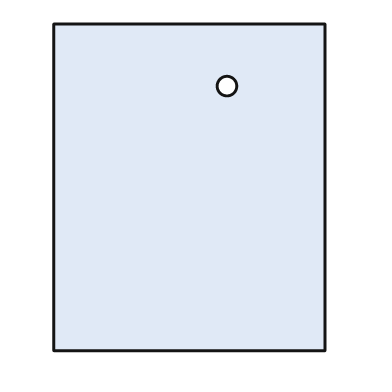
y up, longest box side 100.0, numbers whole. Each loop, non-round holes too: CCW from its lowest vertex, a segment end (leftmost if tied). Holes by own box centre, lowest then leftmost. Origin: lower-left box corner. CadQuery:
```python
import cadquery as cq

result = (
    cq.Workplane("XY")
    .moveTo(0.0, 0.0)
    .lineTo(83.0, 0.0)
    .lineTo(83.0, 100.0)
    .lineTo(0.0, 100.0)
    .close()
    .moveTo(53.0, 81.0)
    .circle(3.0)
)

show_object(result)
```